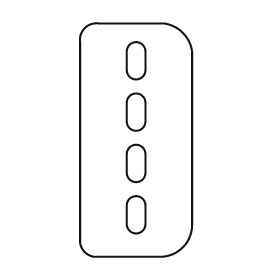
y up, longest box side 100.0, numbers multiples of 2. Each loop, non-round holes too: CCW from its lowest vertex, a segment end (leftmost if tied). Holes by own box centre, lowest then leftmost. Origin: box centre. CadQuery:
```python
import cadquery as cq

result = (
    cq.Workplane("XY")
    .moveTo(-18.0, -50.0)
    .lineTo(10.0, -50.0)
    .threePointArc((20.0, -46.0), (24.0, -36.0))
    .lineTo(24.0, 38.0)
    .threePointArc((20.0, 46.0), (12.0, 50.0))
    .lineTo(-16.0, 50.0)
    .threePointArc((-22.0, 48.0), (-24.0, 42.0))
    .lineTo(-24.0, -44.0)
    .threePointArc((-22.0, -48.0), (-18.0, -50.0))
    .close()
    .moveTo(-4.0, -36.0)
    .threePointArc((0.0, -40.0), (4.0, -36.0))
    .lineTo(4.0, -28.0)
    .threePointArc((0.0, -24.0), (-4.0, -28.0))
    .close()
    .moveTo(-4.0, -14.0)
    .threePointArc((0.0, -18.0), (4.0, -14.0))
    .lineTo(4.0, -6.0)
    .threePointArc((0.0, -2.0), (-4.0, -6.0))
    .close()
    .moveTo(-4.0, 8.0)
    .threePointArc((0.0, 4.0), (4.0, 8.0))
    .lineTo(4.0, 16.0)
    .threePointArc((0.0, 20.0), (-4.0, 16.0))
    .close()
    .moveTo(-4.0, 30.0)
    .threePointArc((0.0, 26.0), (4.0, 30.0))
    .lineTo(4.0, 38.0)
    .threePointArc((0.0, 42.0), (-4.0, 38.0))
    .close()
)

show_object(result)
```